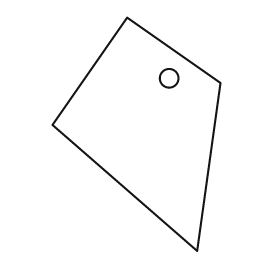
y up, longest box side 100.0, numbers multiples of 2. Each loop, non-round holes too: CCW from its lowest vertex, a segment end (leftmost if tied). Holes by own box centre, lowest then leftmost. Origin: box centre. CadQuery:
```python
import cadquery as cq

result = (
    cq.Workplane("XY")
    .moveTo(26.0, -50.0)
    .lineTo(36.0, 22.0)
    .lineTo(-4.0, 50.0)
    .lineTo(-36.0, 4.0)
    .close()
    .moveTo(14.0, 24.0)
    .circle(4.0)
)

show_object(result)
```